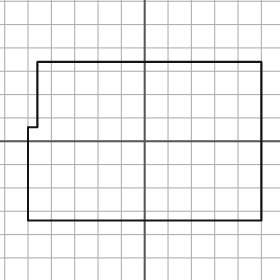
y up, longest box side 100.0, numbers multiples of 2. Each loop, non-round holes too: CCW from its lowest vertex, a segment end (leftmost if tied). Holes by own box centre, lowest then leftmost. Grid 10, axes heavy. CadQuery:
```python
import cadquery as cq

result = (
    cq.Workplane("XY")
    .moveTo(-50.0, -34.0)
    .lineTo(50.0, -34.0)
    .lineTo(50.0, 34.0)
    .lineTo(-46.0, 34.0)
    .lineTo(-46.0, 6.0)
    .lineTo(-50.0, 6.0)
    .close()
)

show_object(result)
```